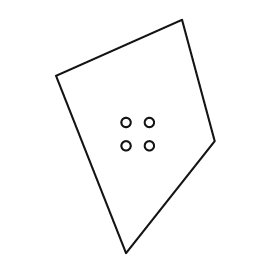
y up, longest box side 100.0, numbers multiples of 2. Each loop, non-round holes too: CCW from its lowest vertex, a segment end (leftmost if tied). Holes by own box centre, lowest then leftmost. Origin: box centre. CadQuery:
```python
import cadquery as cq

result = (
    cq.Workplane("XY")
    .moveTo(-4.0, -50.0)
    .lineTo(34.0, -2.0)
    .lineTo(20.0, 50.0)
    .lineTo(-34.0, 26.0)
    .close()
    .moveTo(-4.0, -4.0)
    .circle(2.0)
    .moveTo(6.0, -4.0)
    .circle(2.0)
    .moveTo(-4.0, 6.0)
    .circle(2.0)
    .moveTo(6.0, 6.0)
    .circle(2.0)
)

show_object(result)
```